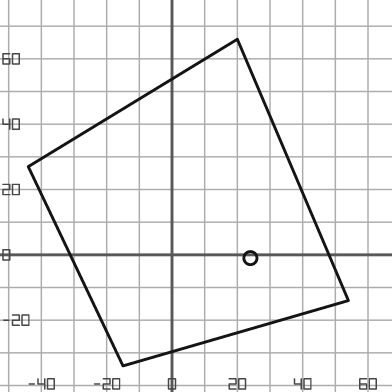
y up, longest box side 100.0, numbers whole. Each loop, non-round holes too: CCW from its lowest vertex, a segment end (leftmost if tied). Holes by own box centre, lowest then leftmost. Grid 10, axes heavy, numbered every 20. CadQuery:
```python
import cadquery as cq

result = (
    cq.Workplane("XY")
    .moveTo(-15.0, -34.0)
    .lineTo(54.0, -14.0)
    .lineTo(20.0, 66.0)
    .lineTo(-44.0, 27.0)
    .close()
    .moveTo(24.0, -1.0)
    .circle(2.0)
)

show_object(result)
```